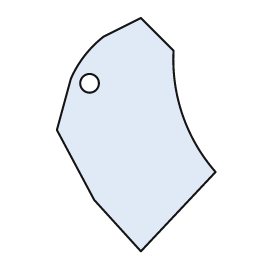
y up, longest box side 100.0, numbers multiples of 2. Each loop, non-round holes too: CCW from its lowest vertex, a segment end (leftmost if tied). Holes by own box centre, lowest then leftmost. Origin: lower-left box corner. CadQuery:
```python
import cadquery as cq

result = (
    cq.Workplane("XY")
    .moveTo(36.0, 0.0)
    .lineTo(68.0, 34.0)
    .threePointArc((54.0, 58.0), (50.0, 86.0))
    .lineTo(36.0, 100.0)
    .lineTo(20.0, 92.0)
    .threePointArc((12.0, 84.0), (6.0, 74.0))
    .lineTo(0.0, 52.0)
    .lineTo(16.0, 22.0)
    .close()
    .moveTo(14.0, 72.0)
    .circle(4.0)
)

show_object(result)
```